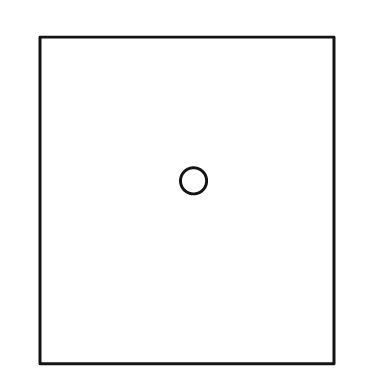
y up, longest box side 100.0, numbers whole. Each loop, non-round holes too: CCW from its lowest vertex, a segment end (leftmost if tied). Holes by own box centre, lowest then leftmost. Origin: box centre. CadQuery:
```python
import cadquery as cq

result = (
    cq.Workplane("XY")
    .moveTo(-45.0, -50.0)
    .lineTo(45.0, -50.0)
    .lineTo(45.0, 50.0)
    .lineTo(-45.0, 50.0)
    .close()
    .moveTo(2.0, 6.0)
    .circle(4.0)
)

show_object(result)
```